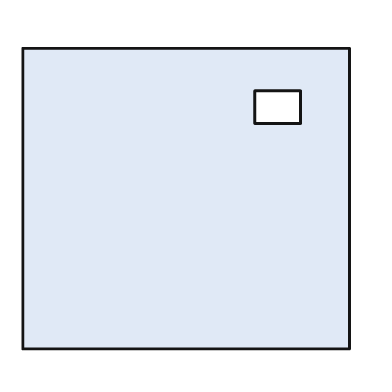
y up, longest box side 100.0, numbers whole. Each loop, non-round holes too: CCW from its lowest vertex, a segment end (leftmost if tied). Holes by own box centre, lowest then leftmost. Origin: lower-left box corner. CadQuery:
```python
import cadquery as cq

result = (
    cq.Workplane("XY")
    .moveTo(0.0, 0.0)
    .lineTo(100.0, 0.0)
    .lineTo(100.0, 92.0)
    .lineTo(0.0, 92.0)
    .close()
    .moveTo(71.0, 69.0)
    .lineTo(85.0, 69.0)
    .lineTo(85.0, 79.0)
    .lineTo(71.0, 79.0)
    .close()
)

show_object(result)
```